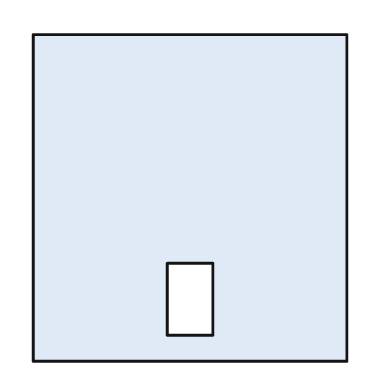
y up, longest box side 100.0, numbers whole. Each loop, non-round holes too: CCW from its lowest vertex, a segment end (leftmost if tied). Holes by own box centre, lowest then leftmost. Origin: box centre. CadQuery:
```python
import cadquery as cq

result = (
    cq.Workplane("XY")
    .moveTo(-48.0, -50.0)
    .lineTo(48.0, -50.0)
    .lineTo(48.0, 50.0)
    .lineTo(-48.0, 50.0)
    .close()
    .moveTo(-7.0, -42.0)
    .lineTo(7.0, -42.0)
    .lineTo(7.0, -20.0)
    .lineTo(-7.0, -20.0)
    .close()
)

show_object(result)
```